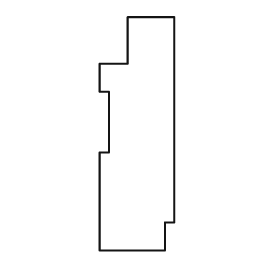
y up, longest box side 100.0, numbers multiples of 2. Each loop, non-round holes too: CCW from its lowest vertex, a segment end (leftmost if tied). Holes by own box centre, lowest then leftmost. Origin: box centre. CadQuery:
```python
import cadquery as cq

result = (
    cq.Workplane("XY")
    .moveTo(-16.0, -50.0)
    .lineTo(12.0, -50.0)
    .lineTo(12.0, -38.0)
    .lineTo(16.0, -38.0)
    .lineTo(16.0, 50.0)
    .lineTo(-4.0, 50.0)
    .lineTo(-4.0, 30.0)
    .lineTo(-16.0, 30.0)
    .lineTo(-16.0, 18.0)
    .lineTo(-12.0, 18.0)
    .lineTo(-12.0, -8.0)
    .lineTo(-16.0, -8.0)
    .close()
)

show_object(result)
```